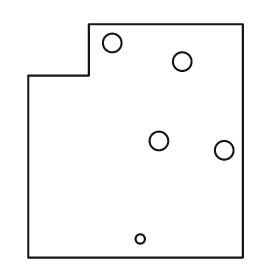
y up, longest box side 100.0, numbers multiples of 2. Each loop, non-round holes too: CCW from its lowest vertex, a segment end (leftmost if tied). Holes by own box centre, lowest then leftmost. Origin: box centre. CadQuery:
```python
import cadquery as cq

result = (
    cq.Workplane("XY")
    .moveTo(-46.0, -50.0)
    .lineTo(46.0, -50.0)
    .lineTo(46.0, 50.0)
    .lineTo(-20.0, 50.0)
    .lineTo(-20.0, 28.0)
    .lineTo(-46.0, 28.0)
    .close()
    .moveTo(2.0, -42.0)
    .circle(2.0)
    .moveTo(38.0, -4.0)
    .circle(4.0)
    .moveTo(10.0, 0.0)
    .circle(4.0)
    .moveTo(20.0, 34.0)
    .circle(4.0)
    .moveTo(-10.0, 42.0)
    .circle(4.0)
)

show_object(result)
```